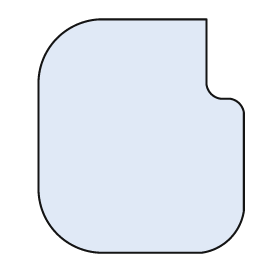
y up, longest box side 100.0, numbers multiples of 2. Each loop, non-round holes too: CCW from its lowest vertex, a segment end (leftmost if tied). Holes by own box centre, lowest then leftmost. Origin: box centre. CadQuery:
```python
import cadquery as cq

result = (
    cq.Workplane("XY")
    .moveTo(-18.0, -50.0)
    .lineTo(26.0, -50.0)
    .threePointArc((38.0, -44.0), (44.0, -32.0))
    .lineTo(44.0, 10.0)
    .threePointArc((42.0, 14.0), (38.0, 16.0))
    .lineTo(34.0, 16.0)
    .threePointArc((30.0, 18.0), (28.0, 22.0))
    .lineTo(28.0, 50.0)
    .lineTo(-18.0, 50.0)
    .threePointArc((-36.0, 42.0), (-44.0, 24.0))
    .lineTo(-44.0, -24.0)
    .threePointArc((-36.0, -42.0), (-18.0, -50.0))
    .close()
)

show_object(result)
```